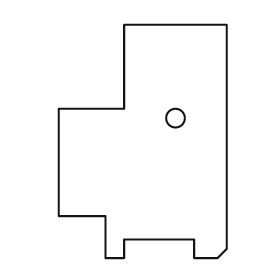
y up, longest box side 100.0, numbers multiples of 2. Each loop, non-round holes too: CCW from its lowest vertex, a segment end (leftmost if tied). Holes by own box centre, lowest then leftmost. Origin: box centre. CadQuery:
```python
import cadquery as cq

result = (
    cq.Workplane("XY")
    .moveTo(-16.0, -50.0)
    .lineTo(-8.0, -50.0)
    .lineTo(-8.0, -42.0)
    .lineTo(22.0, -42.0)
    .lineTo(22.0, -50.0)
    .lineTo(32.0, -50.0)
    .lineTo(36.0, -46.0)
    .lineTo(36.0, 50.0)
    .lineTo(-8.0, 50.0)
    .lineTo(-8.0, 14.0)
    .lineTo(-36.0, 14.0)
    .lineTo(-36.0, -32.0)
    .lineTo(-16.0, -32.0)
    .close()
    .moveTo(14.0, 10.0)
    .circle(4.0)
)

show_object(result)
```